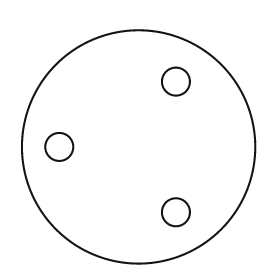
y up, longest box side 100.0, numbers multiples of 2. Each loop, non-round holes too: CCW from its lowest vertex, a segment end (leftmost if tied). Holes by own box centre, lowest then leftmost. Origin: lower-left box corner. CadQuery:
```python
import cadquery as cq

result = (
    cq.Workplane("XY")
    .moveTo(50.0, 50.0)
    .circle(50.0)
    .moveTo(66.0, 22.0)
    .circle(6.0)
    .moveTo(16.0, 50.0)
    .circle(6.0)
    .moveTo(66.0, 78.0)
    .circle(6.0)
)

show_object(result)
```